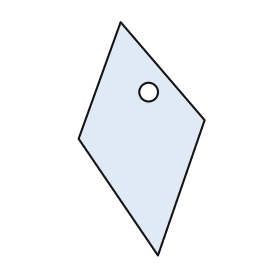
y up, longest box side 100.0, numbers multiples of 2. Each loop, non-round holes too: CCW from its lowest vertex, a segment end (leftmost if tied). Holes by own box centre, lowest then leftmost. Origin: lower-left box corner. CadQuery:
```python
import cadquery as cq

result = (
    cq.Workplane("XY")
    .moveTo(34.0, 0.0)
    .lineTo(54.0, 58.0)
    .lineTo(18.0, 100.0)
    .lineTo(0.0, 50.0)
    .close()
    .moveTo(30.0, 70.0)
    .circle(4.0)
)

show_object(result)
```